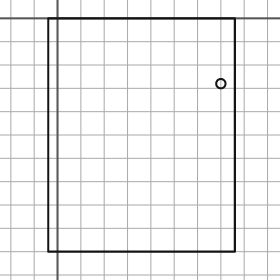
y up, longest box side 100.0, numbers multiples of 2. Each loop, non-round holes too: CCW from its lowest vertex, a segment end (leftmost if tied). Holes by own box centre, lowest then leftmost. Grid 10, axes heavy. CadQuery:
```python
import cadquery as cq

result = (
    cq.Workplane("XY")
    .moveTo(-4.0, -100.0)
    .lineTo(76.0, -100.0)
    .lineTo(76.0, 0.0)
    .lineTo(-4.0, 0.0)
    .close()
    .moveTo(70.0, -28.0)
    .circle(2.0)
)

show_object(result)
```